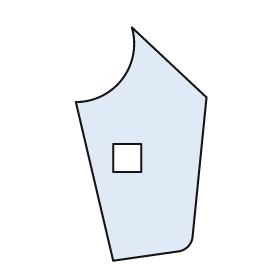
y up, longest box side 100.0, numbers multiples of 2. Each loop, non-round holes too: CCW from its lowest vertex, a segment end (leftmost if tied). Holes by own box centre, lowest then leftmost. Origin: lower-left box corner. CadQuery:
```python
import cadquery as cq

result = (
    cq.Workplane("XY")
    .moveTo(16.0, 0.0)
    .lineTo(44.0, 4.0)
    .threePointArc((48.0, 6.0), (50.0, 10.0))
    .lineTo(56.0, 70.0)
    .lineTo(24.0, 100.0)
    .threePointArc((20.0, 78.0), (0.0, 68.0))
    .close()
    .moveTo(16.0, 38.0)
    .lineTo(28.0, 38.0)
    .lineTo(28.0, 50.0)
    .lineTo(16.0, 50.0)
    .close()
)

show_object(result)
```